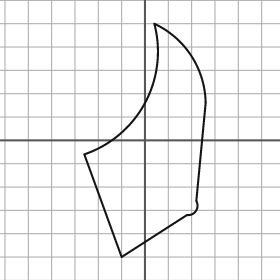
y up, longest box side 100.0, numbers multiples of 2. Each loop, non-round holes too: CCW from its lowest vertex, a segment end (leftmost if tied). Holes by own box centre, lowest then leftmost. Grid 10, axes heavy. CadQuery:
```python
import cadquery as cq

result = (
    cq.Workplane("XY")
    .moveTo(-10.0, -50.0)
    .lineTo(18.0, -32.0)
    .threePointArc((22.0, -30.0), (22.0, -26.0))
    .lineTo(26.0, 16.0)
    .threePointArc((20.0, 36.0), (4.0, 50.0))
    .threePointArc((0.0, 16.0), (-26.0, -6.0))
    .close()
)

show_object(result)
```